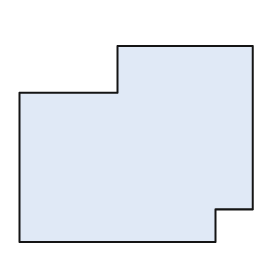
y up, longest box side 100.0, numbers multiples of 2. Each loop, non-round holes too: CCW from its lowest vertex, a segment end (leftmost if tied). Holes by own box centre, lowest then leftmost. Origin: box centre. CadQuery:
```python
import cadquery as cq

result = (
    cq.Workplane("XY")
    .moveTo(-50.0, -42.0)
    .lineTo(34.0, -42.0)
    .lineTo(34.0, -28.0)
    .lineTo(50.0, -28.0)
    .lineTo(50.0, 42.0)
    .lineTo(-8.0, 42.0)
    .lineTo(-8.0, 22.0)
    .lineTo(-50.0, 22.0)
    .close()
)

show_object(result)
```